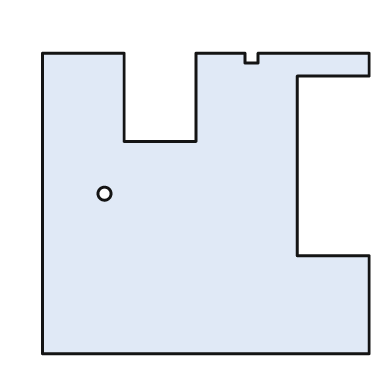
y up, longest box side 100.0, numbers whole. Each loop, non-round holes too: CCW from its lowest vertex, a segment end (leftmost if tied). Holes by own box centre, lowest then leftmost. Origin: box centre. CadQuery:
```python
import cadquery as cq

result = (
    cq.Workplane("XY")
    .moveTo(-50.0, -46.0)
    .lineTo(50.0, -46.0)
    .lineTo(50.0, -16.0)
    .lineTo(28.0, -16.0)
    .lineTo(28.0, 39.0)
    .lineTo(50.0, 39.0)
    .lineTo(50.0, 46.0)
    .lineTo(16.0, 46.0)
    .lineTo(16.0, 43.0)
    .lineTo(12.0, 43.0)
    .lineTo(12.0, 46.0)
    .lineTo(-3.0, 46.0)
    .lineTo(-3.0, 19.0)
    .lineTo(-25.0, 19.0)
    .lineTo(-25.0, 46.0)
    .lineTo(-50.0, 46.0)
    .close()
    .moveTo(-31.0, 3.0)
    .circle(2.0)
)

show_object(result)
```